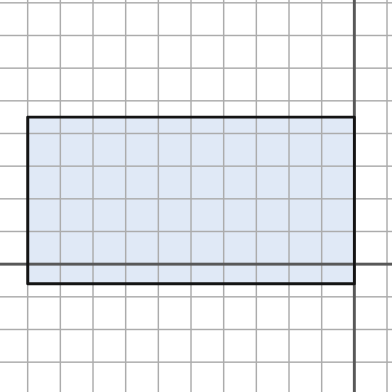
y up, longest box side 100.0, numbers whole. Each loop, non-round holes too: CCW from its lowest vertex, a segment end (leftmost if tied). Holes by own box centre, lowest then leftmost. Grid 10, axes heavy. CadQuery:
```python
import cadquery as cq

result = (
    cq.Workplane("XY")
    .moveTo(-100.0, -6.0)
    .lineTo(0.0, -6.0)
    .lineTo(0.0, 45.0)
    .lineTo(-100.0, 45.0)
    .close()
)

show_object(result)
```